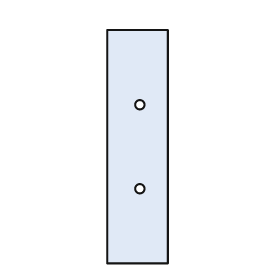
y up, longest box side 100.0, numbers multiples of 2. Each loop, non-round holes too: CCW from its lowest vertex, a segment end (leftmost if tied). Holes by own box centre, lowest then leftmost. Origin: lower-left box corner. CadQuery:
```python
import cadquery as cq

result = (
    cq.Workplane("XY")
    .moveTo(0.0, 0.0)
    .lineTo(26.0, 0.0)
    .lineTo(26.0, 100.0)
    .lineTo(0.0, 100.0)
    .close()
    .moveTo(14.0, 32.0)
    .circle(2.0)
    .moveTo(14.0, 68.0)
    .circle(2.0)
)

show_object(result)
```